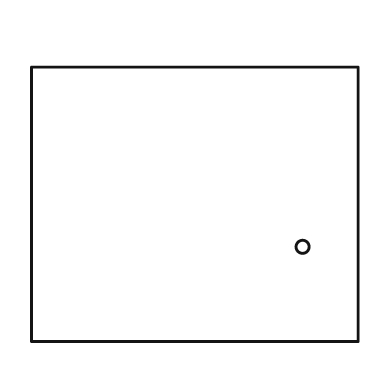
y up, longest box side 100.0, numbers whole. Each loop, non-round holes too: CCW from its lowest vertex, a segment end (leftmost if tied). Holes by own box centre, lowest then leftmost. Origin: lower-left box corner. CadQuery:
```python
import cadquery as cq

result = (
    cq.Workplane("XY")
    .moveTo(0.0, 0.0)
    .lineTo(100.0, 0.0)
    .lineTo(100.0, 84.0)
    .lineTo(0.0, 84.0)
    .close()
    .moveTo(83.0, 29.0)
    .circle(2.0)
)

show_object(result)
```